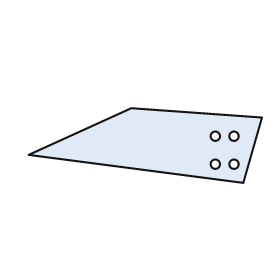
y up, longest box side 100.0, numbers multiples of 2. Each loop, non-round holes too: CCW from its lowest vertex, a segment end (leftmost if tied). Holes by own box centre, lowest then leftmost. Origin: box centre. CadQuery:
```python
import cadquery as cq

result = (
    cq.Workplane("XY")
    .moveTo(42.0, -16.0)
    .lineTo(50.0, 12.0)
    .lineTo(-6.0, 16.0)
    .lineTo(-50.0, -4.0)
    .close()
    .moveTo(30.0, -8.0)
    .circle(2.0)
    .moveTo(38.0, -8.0)
    .circle(2.0)
    .moveTo(30.0, 4.0)
    .circle(2.0)
    .moveTo(38.0, 4.0)
    .circle(2.0)
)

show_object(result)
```